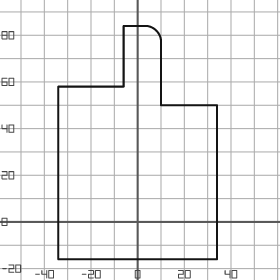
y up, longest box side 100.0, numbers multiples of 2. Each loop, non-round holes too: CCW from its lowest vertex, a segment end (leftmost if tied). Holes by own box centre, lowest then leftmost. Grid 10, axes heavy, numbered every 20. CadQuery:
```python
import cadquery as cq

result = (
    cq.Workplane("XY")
    .moveTo(-34.0, -16.0)
    .lineTo(34.0, -16.0)
    .lineTo(34.0, 50.0)
    .lineTo(10.0, 50.0)
    .lineTo(10.0, 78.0)
    .threePointArc((8.0, 82.0), (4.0, 84.0))
    .lineTo(-6.0, 84.0)
    .lineTo(-6.0, 58.0)
    .lineTo(-34.0, 58.0)
    .close()
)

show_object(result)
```